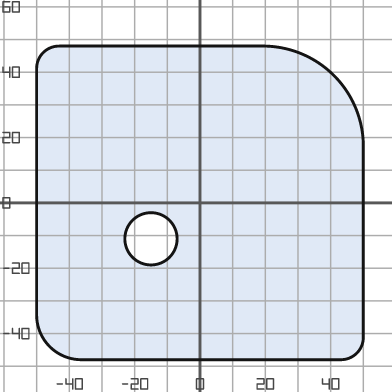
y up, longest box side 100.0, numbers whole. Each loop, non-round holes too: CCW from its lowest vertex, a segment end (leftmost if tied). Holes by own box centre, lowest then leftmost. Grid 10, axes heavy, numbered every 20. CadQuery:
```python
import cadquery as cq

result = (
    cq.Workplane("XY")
    .moveTo(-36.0, -48.0)
    .lineTo(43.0, -48.0)
    .threePointArc((48.0, -46.0), (50.0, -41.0))
    .lineTo(50.0, 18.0)
    .threePointArc((41.0, 39.0), (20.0, 48.0))
    .lineTo(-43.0, 48.0)
    .threePointArc((-48.0, 46.0), (-50.0, 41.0))
    .lineTo(-50.0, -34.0)
    .threePointArc((-46.0, -44.0), (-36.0, -48.0))
    .close()
    .moveTo(-15.0, -11.0)
    .circle(8.0)
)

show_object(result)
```